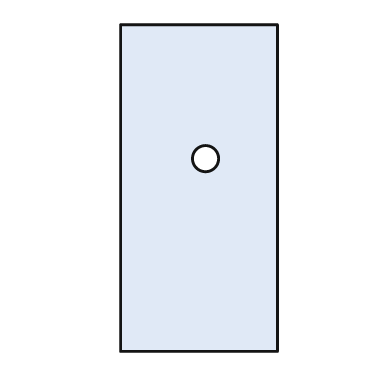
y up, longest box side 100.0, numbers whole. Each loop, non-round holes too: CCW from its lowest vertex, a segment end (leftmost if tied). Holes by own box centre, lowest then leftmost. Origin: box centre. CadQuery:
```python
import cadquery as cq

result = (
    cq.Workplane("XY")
    .moveTo(-24.0, -50.0)
    .lineTo(24.0, -50.0)
    .lineTo(24.0, 50.0)
    .lineTo(-24.0, 50.0)
    .close()
    .moveTo(2.0, 9.0)
    .circle(4.0)
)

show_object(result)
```